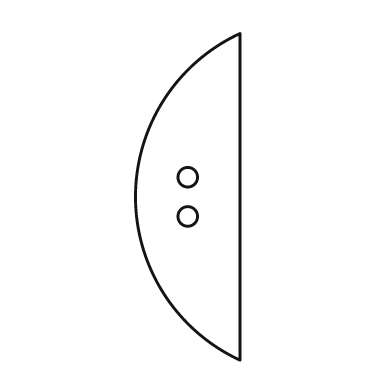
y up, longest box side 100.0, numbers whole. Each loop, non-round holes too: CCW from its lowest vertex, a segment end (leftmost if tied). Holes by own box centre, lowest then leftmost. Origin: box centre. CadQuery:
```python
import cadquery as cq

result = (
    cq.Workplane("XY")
    .moveTo(16.0, -50.0)
    .lineTo(16.0, 50.0)
    .threePointArc((-16.0, 0.0), (16.0, -50.0))
    .close()
    .moveTo(0.0, -6.0)
    .circle(3.0)
    .moveTo(0.0, 6.0)
    .circle(3.0)
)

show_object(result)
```